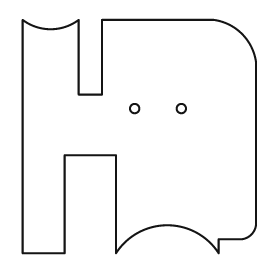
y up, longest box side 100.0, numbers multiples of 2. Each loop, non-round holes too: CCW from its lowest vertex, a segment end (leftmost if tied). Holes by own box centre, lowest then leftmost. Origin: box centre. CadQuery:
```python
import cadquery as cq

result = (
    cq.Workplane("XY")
    .moveTo(-50.0, -50.0)
    .lineTo(-32.0, -50.0)
    .lineTo(-32.0, -8.0)
    .lineTo(-10.0, -8.0)
    .lineTo(-10.0, -50.0)
    .threePointArc((12.0, -38.0), (34.0, -50.0))
    .lineTo(34.0, -44.0)
    .lineTo(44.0, -44.0)
    .threePointArc((48.0, -42.0), (50.0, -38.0))
    .lineTo(50.0, 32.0)
    .threePointArc((44.0, 44.0), (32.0, 50.0))
    .lineTo(-16.0, 50.0)
    .lineTo(-16.0, 18.0)
    .lineTo(-26.0, 18.0)
    .lineTo(-26.0, 50.0)
    .threePointArc((-38.0, 46.0), (-50.0, 50.0))
    .close()
    .moveTo(-2.0, 12.0)
    .circle(2.0)
    .moveTo(18.0, 12.0)
    .circle(2.0)
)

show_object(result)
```